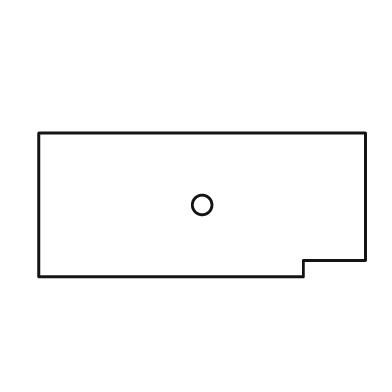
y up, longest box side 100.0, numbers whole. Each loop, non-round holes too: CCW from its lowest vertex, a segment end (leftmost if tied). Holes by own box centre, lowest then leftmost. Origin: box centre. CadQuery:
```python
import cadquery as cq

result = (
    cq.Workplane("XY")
    .moveTo(-50.0, -22.0)
    .lineTo(31.0, -22.0)
    .lineTo(31.0, -17.0)
    .lineTo(50.0, -17.0)
    .lineTo(50.0, 22.0)
    .lineTo(-50.0, 22.0)
    .close()
    .moveTo(0.0, 0.0)
    .circle(3.0)
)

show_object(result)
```